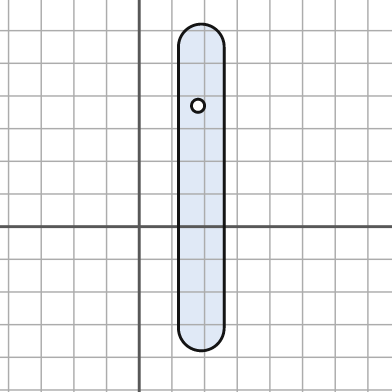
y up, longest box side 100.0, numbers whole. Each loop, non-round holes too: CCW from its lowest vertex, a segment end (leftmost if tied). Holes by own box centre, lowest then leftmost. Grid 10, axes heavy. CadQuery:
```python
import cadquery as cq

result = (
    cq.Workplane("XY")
    .moveTo(12.0, -31.0)
    .threePointArc((19.0, -38.0), (26.0, -31.0))
    .lineTo(26.0, 55.0)
    .threePointArc((19.0, 62.0), (12.0, 55.0))
    .close()
    .moveTo(18.0, 37.0)
    .circle(2.0)
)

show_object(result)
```